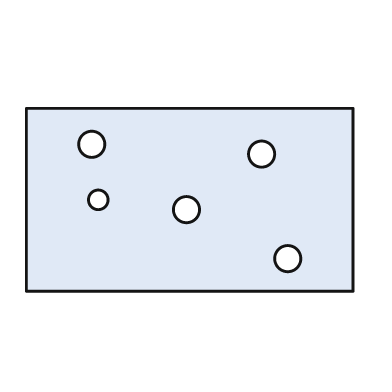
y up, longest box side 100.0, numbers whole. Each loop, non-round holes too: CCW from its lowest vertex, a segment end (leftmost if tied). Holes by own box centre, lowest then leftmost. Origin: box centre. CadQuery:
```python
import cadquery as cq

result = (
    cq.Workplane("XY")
    .moveTo(-50.0, -28.0)
    .lineTo(50.0, -28.0)
    .lineTo(50.0, 28.0)
    .lineTo(-50.0, 28.0)
    .close()
    .moveTo(30.0, -18.0)
    .circle(4.0)
    .moveTo(-1.0, -3.0)
    .circle(4.0)
    .moveTo(-28.0, 0.0)
    .circle(3.0)
    .moveTo(22.0, 14.0)
    .circle(4.0)
    .moveTo(-30.0, 17.0)
    .circle(4.0)
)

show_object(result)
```